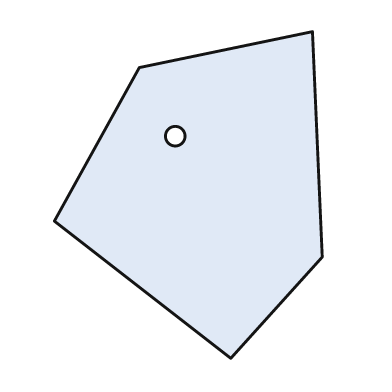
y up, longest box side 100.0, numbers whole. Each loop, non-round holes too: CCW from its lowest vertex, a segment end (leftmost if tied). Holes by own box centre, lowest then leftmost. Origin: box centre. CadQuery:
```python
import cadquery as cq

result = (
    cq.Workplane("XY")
    .moveTo(13.0, -50.0)
    .lineTo(41.0, -19.0)
    .lineTo(38.0, 50.0)
    .lineTo(-15.0, 39.0)
    .lineTo(-41.0, -8.0)
    .close()
    .moveTo(-4.0, 18.0)
    .circle(3.0)
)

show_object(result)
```